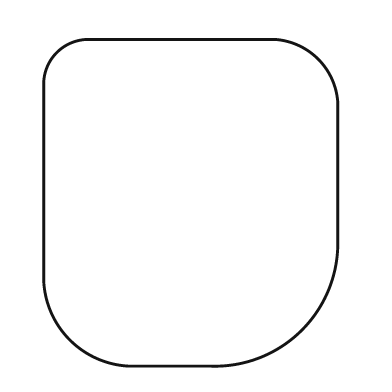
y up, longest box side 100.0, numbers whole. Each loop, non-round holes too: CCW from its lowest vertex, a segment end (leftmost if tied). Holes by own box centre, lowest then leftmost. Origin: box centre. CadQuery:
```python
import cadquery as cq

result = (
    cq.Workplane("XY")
    .moveTo(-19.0, -50.0)
    .lineTo(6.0, -50.0)
    .threePointArc((34.0, -39.0), (45.0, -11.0))
    .lineTo(45.0, 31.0)
    .threePointArc((39.0, 44.0), (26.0, 50.0))
    .lineTo(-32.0, 50.0)
    .threePointArc((-41.0, 46.0), (-45.0, 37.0))
    .lineTo(-45.0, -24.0)
    .threePointArc((-37.0, -42.0), (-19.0, -50.0))
    .close()
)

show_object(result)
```